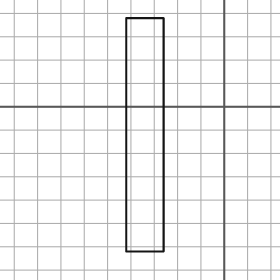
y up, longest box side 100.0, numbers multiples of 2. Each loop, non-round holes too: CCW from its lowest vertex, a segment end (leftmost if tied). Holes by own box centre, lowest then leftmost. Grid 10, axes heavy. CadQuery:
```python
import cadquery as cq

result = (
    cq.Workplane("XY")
    .moveTo(-42.0, -62.0)
    .lineTo(-26.0, -62.0)
    .lineTo(-26.0, 38.0)
    .lineTo(-42.0, 38.0)
    .close()
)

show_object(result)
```